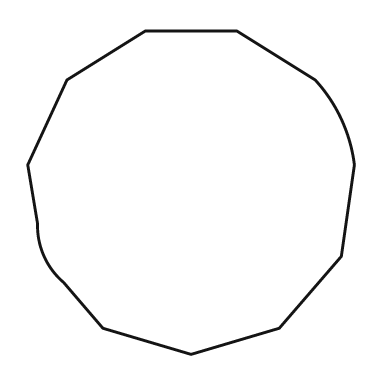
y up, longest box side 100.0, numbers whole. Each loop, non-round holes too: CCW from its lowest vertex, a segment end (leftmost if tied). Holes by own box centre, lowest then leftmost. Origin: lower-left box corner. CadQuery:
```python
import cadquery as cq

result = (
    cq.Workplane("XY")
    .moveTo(50.0, 0.0)
    .lineTo(77.0, 8.0)
    .lineTo(96.0, 30.0)
    .lineTo(100.0, 58.0)
    .threePointArc((96.0, 72.0), (88.0, 84.0))
    .lineTo(64.0, 99.0)
    .lineTo(36.0, 99.0)
    .lineTo(12.0, 84.0)
    .lineTo(0.0, 58.0)
    .lineTo(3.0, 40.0)
    .threePointArc((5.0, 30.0), (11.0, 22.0))
    .lineTo(23.0, 8.0)
    .close()
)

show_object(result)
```